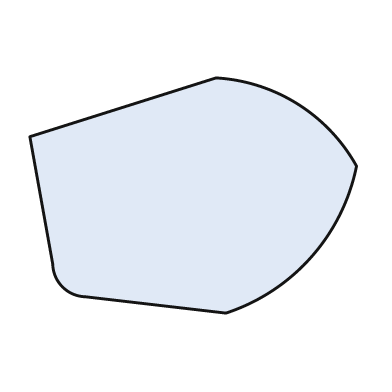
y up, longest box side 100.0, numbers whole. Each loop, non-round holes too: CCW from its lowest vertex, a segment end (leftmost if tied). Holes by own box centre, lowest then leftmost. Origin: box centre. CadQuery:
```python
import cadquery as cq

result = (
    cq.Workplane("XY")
    .moveTo(10.0, -36.0)
    .threePointArc((36.0, -19.0), (50.0, 9.0))
    .threePointArc((32.0, 28.0), (7.0, 36.0))
    .lineTo(-50.0, 18.0)
    .lineTo(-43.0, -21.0)
    .threePointArc((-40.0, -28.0), (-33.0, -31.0))
    .close()
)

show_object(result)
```